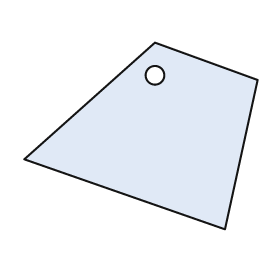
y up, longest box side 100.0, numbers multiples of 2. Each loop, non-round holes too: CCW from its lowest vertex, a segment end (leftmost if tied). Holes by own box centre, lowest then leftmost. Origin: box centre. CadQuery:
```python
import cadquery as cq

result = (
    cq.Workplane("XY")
    .moveTo(36.0, -40.0)
    .lineTo(50.0, 24.0)
    .lineTo(6.0, 40.0)
    .lineTo(-50.0, -10.0)
    .close()
    .moveTo(6.0, 26.0)
    .circle(4.0)
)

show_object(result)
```